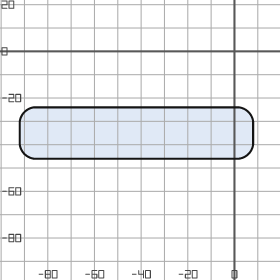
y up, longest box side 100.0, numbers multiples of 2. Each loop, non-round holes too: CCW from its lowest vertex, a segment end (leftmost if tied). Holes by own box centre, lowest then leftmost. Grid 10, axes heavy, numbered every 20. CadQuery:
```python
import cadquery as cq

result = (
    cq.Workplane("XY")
    .moveTo(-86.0, -46.0)
    .lineTo(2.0, -46.0)
    .threePointArc((6.0, -44.0), (8.0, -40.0))
    .lineTo(8.0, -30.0)
    .threePointArc((6.0, -26.0), (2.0, -24.0))
    .lineTo(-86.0, -24.0)
    .threePointArc((-90.0, -26.0), (-92.0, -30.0))
    .lineTo(-92.0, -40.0)
    .threePointArc((-90.0, -44.0), (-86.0, -46.0))
    .close()
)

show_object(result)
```